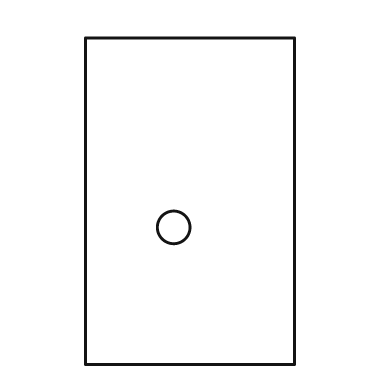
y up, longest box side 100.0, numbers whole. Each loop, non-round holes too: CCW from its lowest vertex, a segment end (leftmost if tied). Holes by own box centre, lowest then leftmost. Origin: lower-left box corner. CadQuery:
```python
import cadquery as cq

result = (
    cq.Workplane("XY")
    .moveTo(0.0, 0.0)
    .lineTo(64.0, 0.0)
    .lineTo(64.0, 100.0)
    .lineTo(0.0, 100.0)
    .close()
    .moveTo(27.0, 42.0)
    .circle(5.0)
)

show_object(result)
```